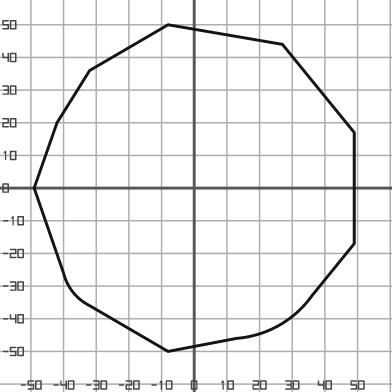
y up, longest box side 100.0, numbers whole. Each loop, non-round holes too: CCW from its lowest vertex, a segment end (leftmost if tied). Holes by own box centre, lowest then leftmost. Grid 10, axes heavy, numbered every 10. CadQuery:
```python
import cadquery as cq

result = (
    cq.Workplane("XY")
    .moveTo(-8.0, -50.0)
    .lineTo(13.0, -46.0)
    .threePointArc((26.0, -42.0), (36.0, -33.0))
    .lineTo(49.0, -17.0)
    .lineTo(49.0, 17.0)
    .lineTo(27.0, 44.0)
    .lineTo(-8.0, 50.0)
    .lineTo(-32.0, 36.0)
    .lineTo(-42.0, 20.0)
    .lineTo(-49.0, 0.0)
    .lineTo(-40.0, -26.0)
    .threePointArc((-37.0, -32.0), (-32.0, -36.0))
    .close()
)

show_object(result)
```